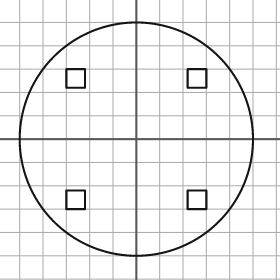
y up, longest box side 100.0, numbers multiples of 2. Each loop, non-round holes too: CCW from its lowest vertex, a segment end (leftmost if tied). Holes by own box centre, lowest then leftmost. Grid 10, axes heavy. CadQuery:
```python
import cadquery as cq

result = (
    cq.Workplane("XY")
    .moveTo(0.0, 0.0)
    .circle(50.0)
    .moveTo(-30.0, -30.0)
    .lineTo(-22.0, -30.0)
    .lineTo(-22.0, -22.0)
    .lineTo(-30.0, -22.0)
    .close()
    .moveTo(22.0, -30.0)
    .lineTo(30.0, -30.0)
    .lineTo(30.0, -22.0)
    .lineTo(22.0, -22.0)
    .close()
    .moveTo(-30.0, 22.0)
    .lineTo(-22.0, 22.0)
    .lineTo(-22.0, 30.0)
    .lineTo(-30.0, 30.0)
    .close()
    .moveTo(22.0, 22.0)
    .lineTo(30.0, 22.0)
    .lineTo(30.0, 30.0)
    .lineTo(22.0, 30.0)
    .close()
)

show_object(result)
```